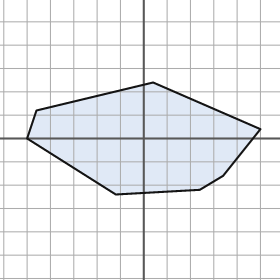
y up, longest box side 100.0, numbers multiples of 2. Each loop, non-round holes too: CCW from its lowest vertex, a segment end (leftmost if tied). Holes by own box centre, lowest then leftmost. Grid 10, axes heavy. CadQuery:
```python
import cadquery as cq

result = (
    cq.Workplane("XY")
    .moveTo(-12.0, -24.0)
    .lineTo(24.0, -22.0)
    .lineTo(34.0, -16.0)
    .lineTo(50.0, 4.0)
    .lineTo(4.0, 24.0)
    .lineTo(-46.0, 12.0)
    .lineTo(-50.0, 0.0)
    .close()
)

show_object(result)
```